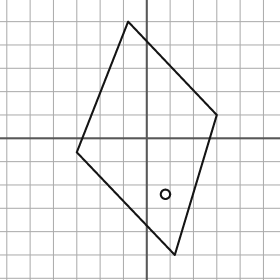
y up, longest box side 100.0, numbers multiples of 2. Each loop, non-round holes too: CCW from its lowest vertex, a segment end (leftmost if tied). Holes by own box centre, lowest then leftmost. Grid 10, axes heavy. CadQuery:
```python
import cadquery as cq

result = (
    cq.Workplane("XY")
    .moveTo(12.0, -50.0)
    .lineTo(30.0, 10.0)
    .lineTo(-8.0, 50.0)
    .lineTo(-30.0, -6.0)
    .close()
    .moveTo(8.0, -24.0)
    .circle(2.0)
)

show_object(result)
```